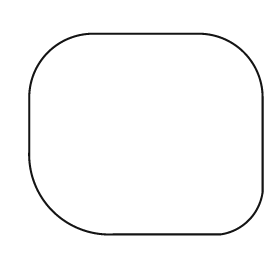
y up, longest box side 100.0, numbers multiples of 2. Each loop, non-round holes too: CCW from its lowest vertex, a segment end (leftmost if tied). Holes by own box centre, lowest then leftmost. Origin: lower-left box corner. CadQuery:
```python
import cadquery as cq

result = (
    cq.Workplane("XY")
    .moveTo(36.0, 0.0)
    .lineTo(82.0, 0.0)
    .threePointArc((94.0, 6.0), (100.0, 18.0))
    .lineTo(100.0, 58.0)
    .threePointArc((92.0, 78.0), (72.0, 86.0))
    .lineTo(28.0, 86.0)
    .threePointArc((8.0, 78.0), (0.0, 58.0))
    .lineTo(0.0, 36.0)
    .threePointArc((10.0, 10.0), (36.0, 0.0))
    .close()
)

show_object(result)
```